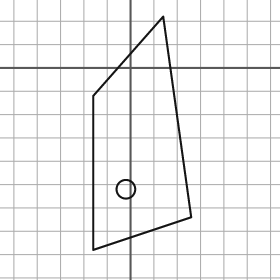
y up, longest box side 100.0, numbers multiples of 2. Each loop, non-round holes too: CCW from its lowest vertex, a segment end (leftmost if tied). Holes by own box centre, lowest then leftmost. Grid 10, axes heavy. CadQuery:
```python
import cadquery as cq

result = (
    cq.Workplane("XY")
    .moveTo(-16.0, -78.0)
    .lineTo(26.0, -64.0)
    .lineTo(14.0, 22.0)
    .lineTo(-16.0, -12.0)
    .close()
    .moveTo(-2.0, -52.0)
    .circle(4.0)
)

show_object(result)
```